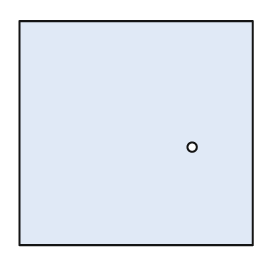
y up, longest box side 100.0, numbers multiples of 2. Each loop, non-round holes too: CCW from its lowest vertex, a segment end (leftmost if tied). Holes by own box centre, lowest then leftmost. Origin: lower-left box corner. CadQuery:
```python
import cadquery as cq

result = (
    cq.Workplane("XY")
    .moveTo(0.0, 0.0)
    .lineTo(100.0, 0.0)
    .lineTo(100.0, 96.0)
    .lineTo(0.0, 96.0)
    .close()
    .moveTo(74.0, 42.0)
    .circle(2.0)
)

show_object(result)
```